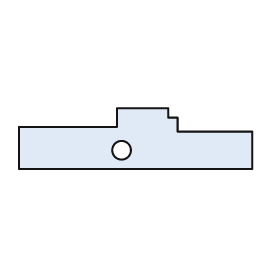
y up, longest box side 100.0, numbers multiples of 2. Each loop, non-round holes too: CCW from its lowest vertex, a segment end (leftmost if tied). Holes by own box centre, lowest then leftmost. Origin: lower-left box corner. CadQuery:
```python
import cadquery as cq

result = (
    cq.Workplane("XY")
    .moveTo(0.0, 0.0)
    .lineTo(100.0, 0.0)
    .lineTo(100.0, 16.0)
    .lineTo(68.0, 16.0)
    .lineTo(68.0, 22.0)
    .lineTo(64.0, 22.0)
    .lineTo(64.0, 26.0)
    .lineTo(42.0, 26.0)
    .lineTo(42.0, 18.0)
    .lineTo(0.0, 18.0)
    .close()
    .moveTo(44.0, 8.0)
    .circle(4.0)
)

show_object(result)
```